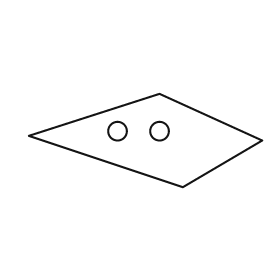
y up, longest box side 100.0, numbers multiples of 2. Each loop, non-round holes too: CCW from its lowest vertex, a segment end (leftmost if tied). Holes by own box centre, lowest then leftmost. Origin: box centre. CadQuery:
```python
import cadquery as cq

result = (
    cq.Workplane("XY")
    .moveTo(16.0, -20.0)
    .lineTo(50.0, 0.0)
    .lineTo(6.0, 20.0)
    .lineTo(-50.0, 2.0)
    .close()
    .moveTo(-12.0, 4.0)
    .circle(4.0)
    .moveTo(6.0, 4.0)
    .circle(4.0)
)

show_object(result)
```